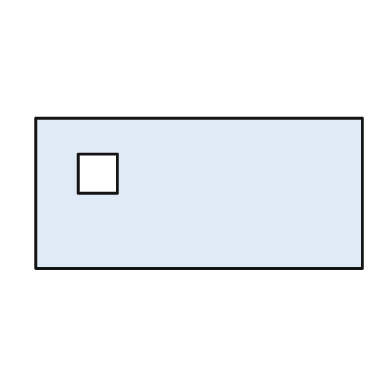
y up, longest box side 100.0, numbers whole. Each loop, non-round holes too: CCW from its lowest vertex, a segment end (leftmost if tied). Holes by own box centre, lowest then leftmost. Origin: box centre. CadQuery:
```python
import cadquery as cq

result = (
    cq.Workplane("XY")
    .moveTo(-50.0, -23.0)
    .lineTo(50.0, -23.0)
    .lineTo(50.0, 23.0)
    .lineTo(-50.0, 23.0)
    .close()
    .moveTo(-37.0, 0.0)
    .lineTo(-25.0, 0.0)
    .lineTo(-25.0, 12.0)
    .lineTo(-37.0, 12.0)
    .close()
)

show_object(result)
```